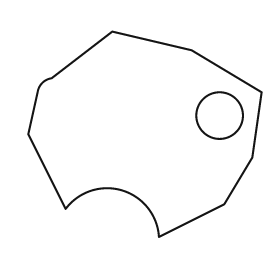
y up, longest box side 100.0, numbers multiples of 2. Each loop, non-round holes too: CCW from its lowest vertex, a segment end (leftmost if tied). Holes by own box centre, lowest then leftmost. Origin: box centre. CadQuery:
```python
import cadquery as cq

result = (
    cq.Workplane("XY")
    .moveTo(6.0, -44.0)
    .lineTo(34.0, -30.0)
    .lineTo(46.0, -10.0)
    .lineTo(50.0, 18.0)
    .lineTo(20.0, 36.0)
    .lineTo(-14.0, 44.0)
    .lineTo(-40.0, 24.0)
    .threePointArc((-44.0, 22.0), (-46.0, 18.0))
    .lineTo(-50.0, 0.0)
    .lineTo(-34.0, -32.0)
    .threePointArc((-10.0, -24.0), (6.0, -44.0))
    .close()
    .moveTo(32.0, 8.0)
    .circle(10.0)
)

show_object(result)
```